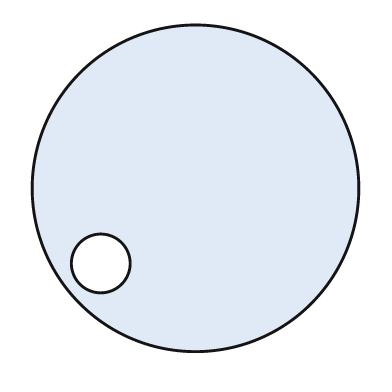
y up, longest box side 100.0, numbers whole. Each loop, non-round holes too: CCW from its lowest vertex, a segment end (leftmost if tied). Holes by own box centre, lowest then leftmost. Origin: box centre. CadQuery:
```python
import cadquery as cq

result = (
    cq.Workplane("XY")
    .moveTo(0.0, 0.0)
    .circle(50.0)
    .moveTo(-29.0, -23.0)
    .circle(9.0)
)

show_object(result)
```